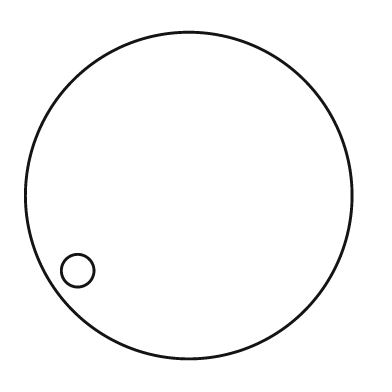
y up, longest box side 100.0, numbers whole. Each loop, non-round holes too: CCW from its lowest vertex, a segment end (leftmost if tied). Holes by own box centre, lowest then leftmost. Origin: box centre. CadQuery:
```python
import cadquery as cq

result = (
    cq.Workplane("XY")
    .moveTo(0.0, 0.0)
    .circle(50.0)
    .moveTo(-34.0, -23.0)
    .circle(5.0)
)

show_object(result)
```